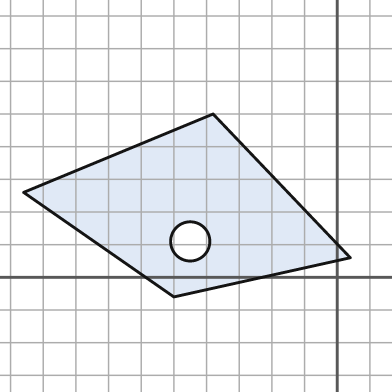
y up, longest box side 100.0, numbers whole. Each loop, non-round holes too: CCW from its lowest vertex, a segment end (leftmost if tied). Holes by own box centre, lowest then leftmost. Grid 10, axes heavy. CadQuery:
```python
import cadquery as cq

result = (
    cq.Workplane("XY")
    .moveTo(-50.0, -6.0)
    .lineTo(4.0, 6.0)
    .lineTo(-38.0, 50.0)
    .lineTo(-96.0, 26.0)
    .close()
    .moveTo(-45.0, 11.0)
    .circle(6.0)
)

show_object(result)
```